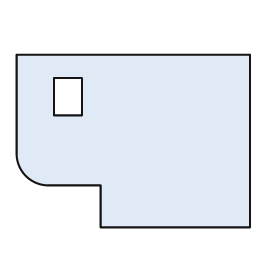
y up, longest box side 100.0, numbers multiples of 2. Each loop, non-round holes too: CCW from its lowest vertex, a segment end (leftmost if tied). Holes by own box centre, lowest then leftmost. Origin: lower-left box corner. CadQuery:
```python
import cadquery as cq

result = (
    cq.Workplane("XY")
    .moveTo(36.0, 0.0)
    .lineTo(100.0, 0.0)
    .lineTo(100.0, 74.0)
    .lineTo(0.0, 74.0)
    .lineTo(0.0, 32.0)
    .threePointArc((4.0, 22.0), (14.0, 18.0))
    .lineTo(36.0, 18.0)
    .close()
    .moveTo(16.0, 48.0)
    .lineTo(28.0, 48.0)
    .lineTo(28.0, 64.0)
    .lineTo(16.0, 64.0)
    .close()
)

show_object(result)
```